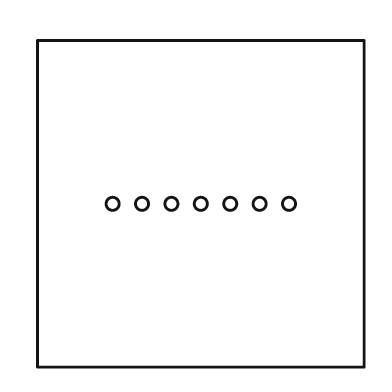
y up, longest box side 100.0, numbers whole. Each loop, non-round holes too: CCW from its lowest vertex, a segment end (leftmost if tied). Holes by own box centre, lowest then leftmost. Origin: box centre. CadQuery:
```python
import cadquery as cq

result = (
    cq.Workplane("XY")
    .moveTo(-50.0, -50.0)
    .lineTo(50.0, -50.0)
    .lineTo(50.0, 50.0)
    .lineTo(-50.0, 50.0)
    .close()
    .moveTo(-27.0, 0.0)
    .circle(2.0)
    .moveTo(-18.0, 0.0)
    .circle(2.0)
    .moveTo(-9.0, 0.0)
    .circle(2.0)
    .moveTo(0.0, 0.0)
    .circle(2.0)
    .moveTo(9.0, 0.0)
    .circle(2.0)
    .moveTo(18.0, 0.0)
    .circle(2.0)
    .moveTo(27.0, 0.0)
    .circle(2.0)
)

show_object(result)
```